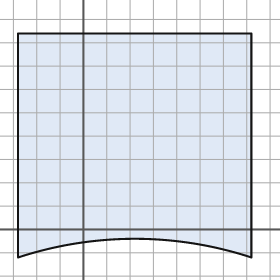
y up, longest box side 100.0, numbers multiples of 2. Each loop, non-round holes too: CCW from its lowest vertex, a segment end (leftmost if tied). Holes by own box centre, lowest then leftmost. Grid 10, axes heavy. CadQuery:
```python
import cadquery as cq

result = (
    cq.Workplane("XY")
    .moveTo(-28.0, -12.0)
    .threePointArc((22.0, -4.0), (72.0, -12.0))
    .lineTo(72.0, 84.0)
    .lineTo(-28.0, 84.0)
    .close()
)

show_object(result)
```